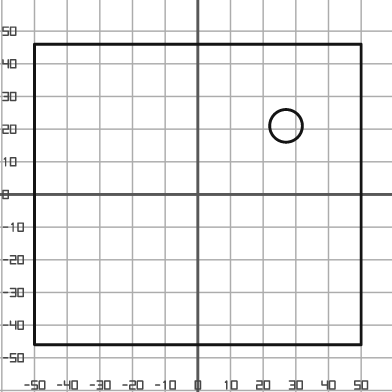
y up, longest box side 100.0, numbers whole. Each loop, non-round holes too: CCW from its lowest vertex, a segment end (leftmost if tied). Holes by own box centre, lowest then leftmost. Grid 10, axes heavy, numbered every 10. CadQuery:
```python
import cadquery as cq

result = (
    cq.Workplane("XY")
    .moveTo(-50.0, -46.0)
    .lineTo(50.0, -46.0)
    .lineTo(50.0, 46.0)
    .lineTo(-50.0, 46.0)
    .close()
    .moveTo(27.0, 21.0)
    .circle(5.0)
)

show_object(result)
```